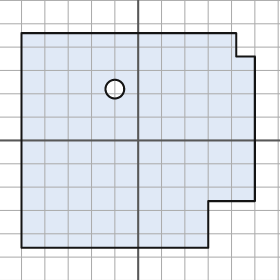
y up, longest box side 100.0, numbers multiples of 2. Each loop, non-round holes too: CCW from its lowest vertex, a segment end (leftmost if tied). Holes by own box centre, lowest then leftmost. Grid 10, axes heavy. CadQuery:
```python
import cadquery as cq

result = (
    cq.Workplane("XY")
    .moveTo(-50.0, -46.0)
    .lineTo(30.0, -46.0)
    .lineTo(30.0, -26.0)
    .lineTo(50.0, -26.0)
    .lineTo(50.0, 36.0)
    .lineTo(42.0, 36.0)
    .lineTo(42.0, 46.0)
    .lineTo(-50.0, 46.0)
    .close()
    .moveTo(-10.0, 22.0)
    .circle(4.0)
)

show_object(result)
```